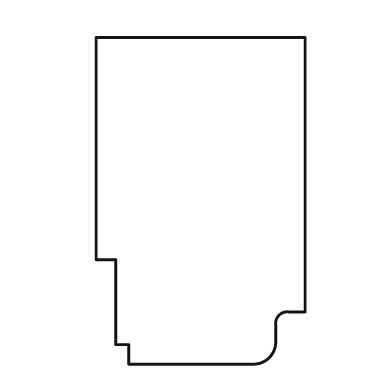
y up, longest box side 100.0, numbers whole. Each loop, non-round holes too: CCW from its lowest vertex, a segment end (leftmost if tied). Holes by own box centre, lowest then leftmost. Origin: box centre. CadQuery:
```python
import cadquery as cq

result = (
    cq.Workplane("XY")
    .moveTo(-22.0, -50.0)
    .lineTo(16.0, -50.0)
    .threePointArc((21.0, -48.0), (23.0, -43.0))
    .lineTo(23.0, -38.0)
    .threePointArc((24.0, -35.0), (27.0, -34.0))
    .lineTo(32.0, -34.0)
    .lineTo(32.0, 50.0)
    .lineTo(-32.0, 50.0)
    .lineTo(-32.0, -18.0)
    .lineTo(-26.0, -18.0)
    .lineTo(-26.0, -44.0)
    .lineTo(-22.0, -44.0)
    .close()
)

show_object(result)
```